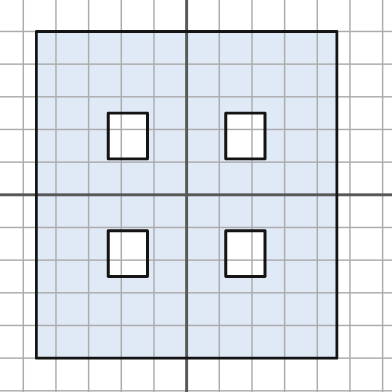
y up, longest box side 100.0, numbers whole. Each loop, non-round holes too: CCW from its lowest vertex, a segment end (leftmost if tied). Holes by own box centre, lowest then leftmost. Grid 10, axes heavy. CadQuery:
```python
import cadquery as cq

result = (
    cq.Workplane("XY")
    .moveTo(-46.0, -50.0)
    .lineTo(46.0, -50.0)
    .lineTo(46.0, 50.0)
    .lineTo(-46.0, 50.0)
    .close()
    .moveTo(-24.0, -25.0)
    .lineTo(-12.0, -25.0)
    .lineTo(-12.0, -11.0)
    .lineTo(-24.0, -11.0)
    .close()
    .moveTo(12.0, -25.0)
    .lineTo(24.0, -25.0)
    .lineTo(24.0, -11.0)
    .lineTo(12.0, -11.0)
    .close()
    .moveTo(-24.0, 11.0)
    .lineTo(-12.0, 11.0)
    .lineTo(-12.0, 25.0)
    .lineTo(-24.0, 25.0)
    .close()
    .moveTo(12.0, 11.0)
    .lineTo(24.0, 11.0)
    .lineTo(24.0, 25.0)
    .lineTo(12.0, 25.0)
    .close()
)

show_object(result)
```